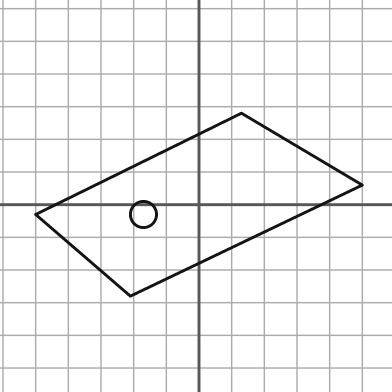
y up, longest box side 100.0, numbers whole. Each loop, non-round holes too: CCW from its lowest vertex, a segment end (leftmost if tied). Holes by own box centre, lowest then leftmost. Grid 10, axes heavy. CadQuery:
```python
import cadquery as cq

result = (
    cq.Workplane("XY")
    .moveTo(-21.0, -28.0)
    .lineTo(50.0, 6.0)
    .lineTo(13.0, 28.0)
    .lineTo(-50.0, -3.0)
    .close()
    .moveTo(-17.0, -3.0)
    .circle(4.0)
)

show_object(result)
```